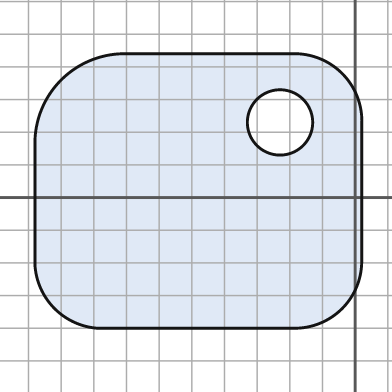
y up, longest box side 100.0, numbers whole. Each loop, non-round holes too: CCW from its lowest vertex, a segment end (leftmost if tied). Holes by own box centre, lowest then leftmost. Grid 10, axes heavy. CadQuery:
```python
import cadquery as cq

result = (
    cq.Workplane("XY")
    .moveTo(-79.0, -40.0)
    .lineTo(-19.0, -40.0)
    .threePointArc((-4.0, -34.0), (2.0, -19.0))
    .lineTo(2.0, 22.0)
    .threePointArc((-4.0, 38.0), (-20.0, 44.0))
    .lineTo(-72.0, 44.0)
    .threePointArc((-90.0, 36.0), (-98.0, 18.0))
    .lineTo(-98.0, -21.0)
    .threePointArc((-92.0, -34.0), (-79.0, -40.0))
    .close()
    .moveTo(-23.0, 23.0)
    .circle(10.0)
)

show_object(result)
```